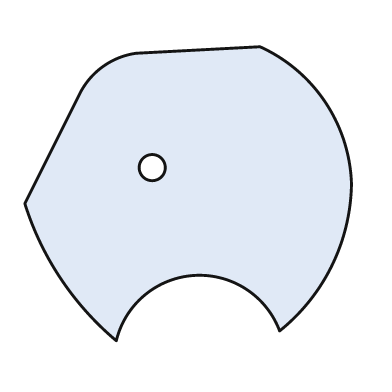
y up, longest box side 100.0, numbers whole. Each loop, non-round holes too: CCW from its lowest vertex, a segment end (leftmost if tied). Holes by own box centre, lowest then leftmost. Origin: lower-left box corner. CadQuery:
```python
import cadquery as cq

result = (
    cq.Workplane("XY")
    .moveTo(28.0, 0.0)
    .threePointArc((52.0, 20.0), (78.0, 3.0))
    .threePointArc((94.0, 23.0), (100.0, 48.0))
    .threePointArc((92.0, 73.0), (72.0, 90.0))
    .lineTo(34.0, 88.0)
    .threePointArc((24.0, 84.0), (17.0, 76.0))
    .lineTo(0.0, 42.0)
    .threePointArc((11.0, 19.0), (28.0, 0.0))
    .close()
    .moveTo(39.0, 53.0)
    .circle(4.0)
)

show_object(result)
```